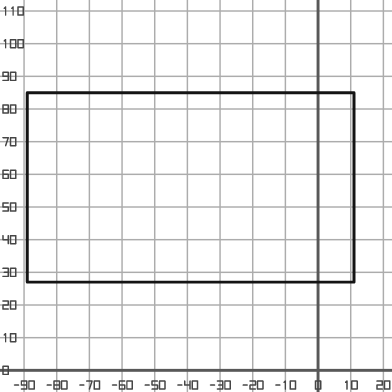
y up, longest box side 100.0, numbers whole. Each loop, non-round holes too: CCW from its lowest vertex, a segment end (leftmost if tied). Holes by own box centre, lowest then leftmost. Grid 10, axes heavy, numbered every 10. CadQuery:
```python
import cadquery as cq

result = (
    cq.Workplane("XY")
    .moveTo(-89.0, 27.0)
    .lineTo(11.0, 27.0)
    .lineTo(11.0, 85.0)
    .lineTo(-89.0, 85.0)
    .close()
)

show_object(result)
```